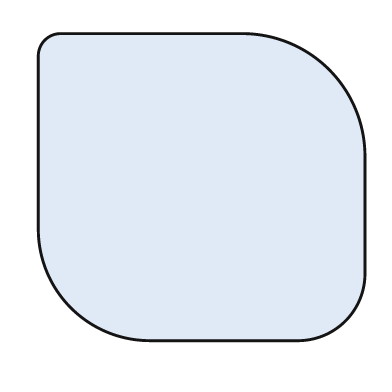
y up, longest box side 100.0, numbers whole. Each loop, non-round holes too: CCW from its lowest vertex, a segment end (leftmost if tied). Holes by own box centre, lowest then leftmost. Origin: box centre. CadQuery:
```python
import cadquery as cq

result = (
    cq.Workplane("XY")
    .moveTo(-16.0, -47.0)
    .lineTo(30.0, -47.0)
    .threePointArc((44.0, -41.0), (50.0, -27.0))
    .lineTo(50.0, 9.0)
    .threePointArc((39.0, 36.0), (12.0, 47.0))
    .lineTo(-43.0, 47.0)
    .threePointArc((-48.0, 45.0), (-50.0, 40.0))
    .lineTo(-50.0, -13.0)
    .threePointArc((-40.0, -37.0), (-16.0, -47.0))
    .close()
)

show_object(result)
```